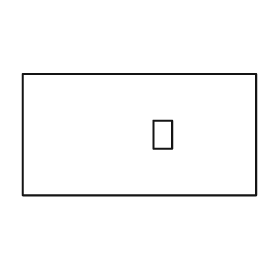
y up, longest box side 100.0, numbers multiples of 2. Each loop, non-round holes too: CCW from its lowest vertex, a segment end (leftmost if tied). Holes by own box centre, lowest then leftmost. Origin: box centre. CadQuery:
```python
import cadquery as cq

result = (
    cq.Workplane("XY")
    .moveTo(-50.0, -26.0)
    .lineTo(50.0, -26.0)
    .lineTo(50.0, 26.0)
    .lineTo(-50.0, 26.0)
    .close()
    .moveTo(6.0, -6.0)
    .lineTo(14.0, -6.0)
    .lineTo(14.0, 6.0)
    .lineTo(6.0, 6.0)
    .close()
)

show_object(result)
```